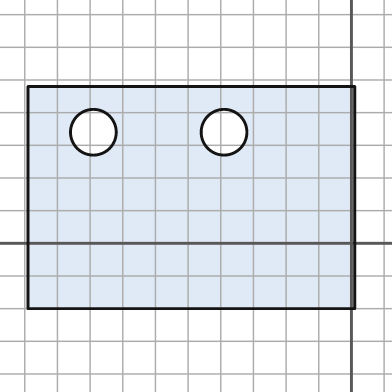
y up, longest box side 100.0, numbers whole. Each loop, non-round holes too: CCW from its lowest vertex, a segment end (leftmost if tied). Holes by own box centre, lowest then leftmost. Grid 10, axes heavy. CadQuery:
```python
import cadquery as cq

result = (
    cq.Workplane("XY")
    .moveTo(-99.0, -20.0)
    .lineTo(1.0, -20.0)
    .lineTo(1.0, 48.0)
    .lineTo(-99.0, 48.0)
    .close()
    .moveTo(-79.0, 34.0)
    .circle(7.0)
    .moveTo(-39.0, 34.0)
    .circle(7.0)
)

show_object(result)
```